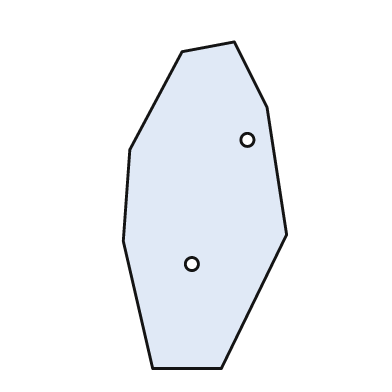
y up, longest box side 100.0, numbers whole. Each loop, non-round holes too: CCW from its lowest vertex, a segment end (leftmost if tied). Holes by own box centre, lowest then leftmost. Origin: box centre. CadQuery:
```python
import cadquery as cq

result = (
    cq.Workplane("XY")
    .moveTo(-16.0, -50.0)
    .lineTo(5.0, -50.0)
    .lineTo(25.0, -9.0)
    .lineTo(19.0, 30.0)
    .lineTo(9.0, 50.0)
    .lineTo(-7.0, 47.0)
    .lineTo(-23.0, 17.0)
    .lineTo(-25.0, -11.0)
    .close()
    .moveTo(-4.0, -18.0)
    .circle(2.0)
    .moveTo(13.0, 20.0)
    .circle(2.0)
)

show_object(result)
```